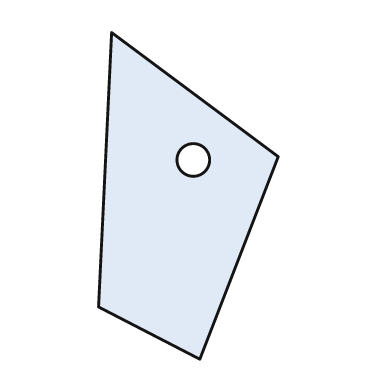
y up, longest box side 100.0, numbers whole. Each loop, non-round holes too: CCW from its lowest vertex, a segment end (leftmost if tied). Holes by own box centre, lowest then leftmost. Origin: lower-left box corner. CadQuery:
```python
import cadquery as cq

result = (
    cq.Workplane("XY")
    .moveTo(31.0, 0.0)
    .lineTo(55.0, 62.0)
    .lineTo(4.0, 100.0)
    .lineTo(0.0, 16.0)
    .close()
    .moveTo(29.0, 61.0)
    .circle(5.0)
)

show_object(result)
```